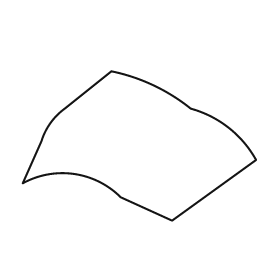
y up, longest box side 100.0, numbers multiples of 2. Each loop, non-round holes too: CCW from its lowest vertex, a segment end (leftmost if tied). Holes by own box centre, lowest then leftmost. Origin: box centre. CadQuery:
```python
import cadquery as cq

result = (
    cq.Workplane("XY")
    .moveTo(14.0, -32.0)
    .lineTo(50.0, -6.0)
    .threePointArc((38.0, 8.0), (22.0, 16.0))
    .threePointArc((6.0, 26.0), (-12.0, 32.0))
    .lineTo(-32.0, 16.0)
    .threePointArc((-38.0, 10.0), (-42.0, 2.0))
    .lineTo(-50.0, -16.0)
    .threePointArc((-28.0, -12.0), (-8.0, -22.0))
    .close()
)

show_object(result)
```